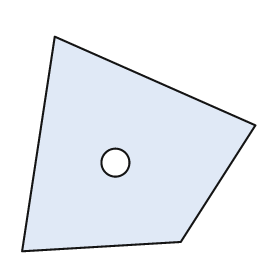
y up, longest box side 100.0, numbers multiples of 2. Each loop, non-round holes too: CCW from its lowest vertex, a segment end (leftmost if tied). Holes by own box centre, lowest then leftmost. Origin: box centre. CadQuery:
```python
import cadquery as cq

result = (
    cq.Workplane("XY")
    .moveTo(-50.0, -46.0)
    .lineTo(18.0, -42.0)
    .lineTo(50.0, 8.0)
    .lineTo(-36.0, 46.0)
    .close()
    .moveTo(-10.0, -8.0)
    .circle(6.0)
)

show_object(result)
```